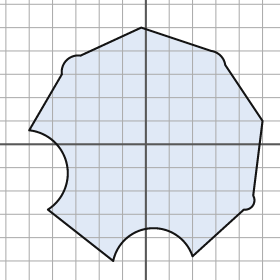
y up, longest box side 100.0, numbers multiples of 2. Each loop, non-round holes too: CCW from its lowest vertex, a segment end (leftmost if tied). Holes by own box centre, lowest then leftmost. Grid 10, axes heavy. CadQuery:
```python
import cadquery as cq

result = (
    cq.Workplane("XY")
    .moveTo(-14.0, -50.0)
    .threePointArc((2.0, -36.0), (20.0, -48.0))
    .lineTo(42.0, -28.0)
    .threePointArc((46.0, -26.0), (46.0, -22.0))
    .lineTo(50.0, 10.0)
    .lineTo(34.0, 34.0)
    .threePointArc((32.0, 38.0), (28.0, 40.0))
    .lineTo(-2.0, 50.0)
    .lineTo(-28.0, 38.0)
    .threePointArc((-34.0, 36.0), (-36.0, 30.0))
    .lineTo(-50.0, 6.0)
    .threePointArc((-34.0, -8.0), (-42.0, -28.0))
    .close()
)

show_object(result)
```